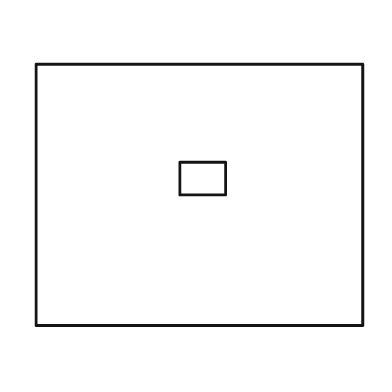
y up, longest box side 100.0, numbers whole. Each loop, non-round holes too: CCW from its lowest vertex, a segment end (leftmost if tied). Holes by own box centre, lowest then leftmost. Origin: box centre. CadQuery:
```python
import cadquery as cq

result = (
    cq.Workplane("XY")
    .moveTo(-50.0, -40.0)
    .lineTo(50.0, -40.0)
    .lineTo(50.0, 40.0)
    .lineTo(-50.0, 40.0)
    .close()
    .moveTo(-6.0, 0.0)
    .lineTo(8.0, 0.0)
    .lineTo(8.0, 10.0)
    .lineTo(-6.0, 10.0)
    .close()
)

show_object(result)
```